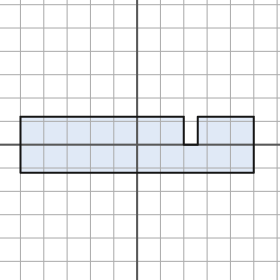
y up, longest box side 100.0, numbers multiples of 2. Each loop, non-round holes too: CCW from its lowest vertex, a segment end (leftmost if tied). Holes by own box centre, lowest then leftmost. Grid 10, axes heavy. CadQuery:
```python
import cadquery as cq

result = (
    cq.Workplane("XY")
    .moveTo(-50.0, -12.0)
    .lineTo(50.0, -12.0)
    .lineTo(50.0, 12.0)
    .lineTo(26.0, 12.0)
    .lineTo(26.0, 0.0)
    .lineTo(20.0, 0.0)
    .lineTo(20.0, 12.0)
    .lineTo(-50.0, 12.0)
    .close()
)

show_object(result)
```